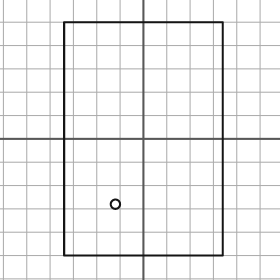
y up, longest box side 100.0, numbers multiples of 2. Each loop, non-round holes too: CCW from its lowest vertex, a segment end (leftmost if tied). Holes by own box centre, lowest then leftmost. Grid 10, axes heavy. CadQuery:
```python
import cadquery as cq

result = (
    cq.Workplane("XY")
    .moveTo(-34.0, -50.0)
    .lineTo(34.0, -50.0)
    .lineTo(34.0, 50.0)
    .lineTo(-34.0, 50.0)
    .close()
    .moveTo(-12.0, -28.0)
    .circle(2.0)
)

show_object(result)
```